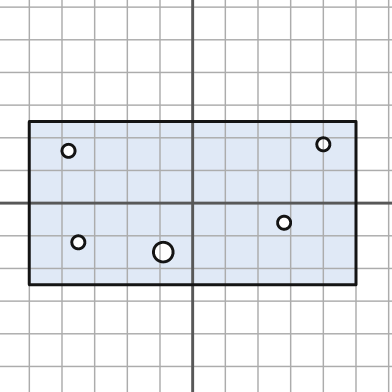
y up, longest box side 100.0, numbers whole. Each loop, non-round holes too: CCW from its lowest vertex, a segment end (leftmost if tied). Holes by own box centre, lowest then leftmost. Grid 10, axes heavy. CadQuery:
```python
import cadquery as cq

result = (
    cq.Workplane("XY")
    .moveTo(-50.0, -25.0)
    .lineTo(50.0, -25.0)
    .lineTo(50.0, 25.0)
    .lineTo(-50.0, 25.0)
    .close()
    .moveTo(-9.0, -15.0)
    .circle(3.0)
    .moveTo(-35.0, -12.0)
    .circle(2.0)
    .moveTo(28.0, -6.0)
    .circle(2.0)
    .moveTo(-38.0, 16.0)
    .circle(2.0)
    .moveTo(40.0, 18.0)
    .circle(2.0)
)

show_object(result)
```